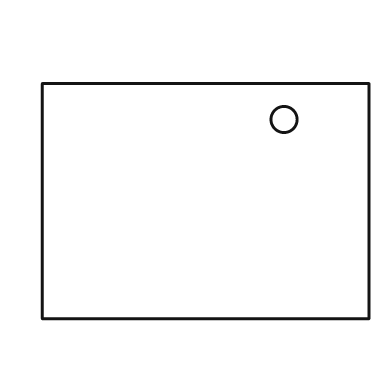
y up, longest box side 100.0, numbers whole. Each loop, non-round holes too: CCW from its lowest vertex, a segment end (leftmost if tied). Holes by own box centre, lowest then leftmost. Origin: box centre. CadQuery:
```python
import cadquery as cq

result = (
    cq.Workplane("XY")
    .moveTo(-50.0, -36.0)
    .lineTo(50.0, -36.0)
    .lineTo(50.0, 36.0)
    .lineTo(-50.0, 36.0)
    .close()
    .moveTo(24.0, 25.0)
    .circle(4.0)
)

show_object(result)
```